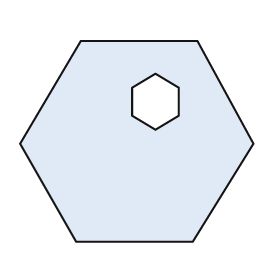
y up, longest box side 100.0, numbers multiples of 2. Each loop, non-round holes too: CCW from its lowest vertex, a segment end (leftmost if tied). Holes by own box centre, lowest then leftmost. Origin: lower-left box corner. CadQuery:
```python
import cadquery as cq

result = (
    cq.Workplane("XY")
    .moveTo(24.0, 0.0)
    .lineTo(74.0, 0.0)
    .lineTo(100.0, 42.0)
    .lineTo(76.0, 86.0)
    .lineTo(26.0, 86.0)
    .lineTo(0.0, 42.0)
    .close()
    .moveTo(58.0, 48.0)
    .lineTo(68.0, 54.0)
    .lineTo(68.0, 66.0)
    .lineTo(58.0, 72.0)
    .lineTo(48.0, 66.0)
    .lineTo(48.0, 54.0)
    .close()
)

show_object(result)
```